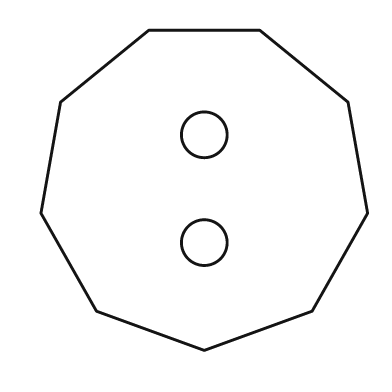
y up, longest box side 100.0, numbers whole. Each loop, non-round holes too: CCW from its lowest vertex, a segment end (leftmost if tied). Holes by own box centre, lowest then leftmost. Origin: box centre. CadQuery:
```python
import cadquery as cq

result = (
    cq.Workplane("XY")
    .moveTo(0.0, -49.0)
    .lineTo(33.0, -37.0)
    .lineTo(50.0, -7.0)
    .lineTo(44.0, 27.0)
    .lineTo(17.0, 49.0)
    .lineTo(-17.0, 49.0)
    .lineTo(-44.0, 27.0)
    .lineTo(-50.0, -7.0)
    .lineTo(-33.0, -37.0)
    .close()
    .moveTo(0.0, -16.0)
    .circle(7.0)
    .moveTo(0.0, 17.0)
    .circle(7.0)
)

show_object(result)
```